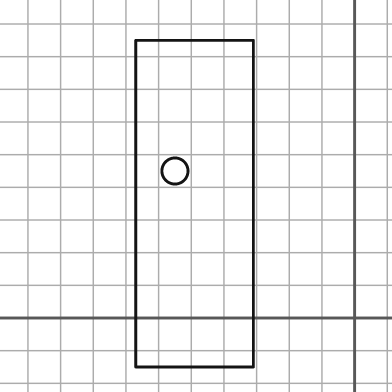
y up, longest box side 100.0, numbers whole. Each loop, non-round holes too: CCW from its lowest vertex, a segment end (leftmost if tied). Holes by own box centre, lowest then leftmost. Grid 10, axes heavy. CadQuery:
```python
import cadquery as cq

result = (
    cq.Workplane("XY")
    .moveTo(-67.0, -15.0)
    .lineTo(-31.0, -15.0)
    .lineTo(-31.0, 85.0)
    .lineTo(-67.0, 85.0)
    .close()
    .moveTo(-55.0, 45.0)
    .circle(4.0)
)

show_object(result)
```